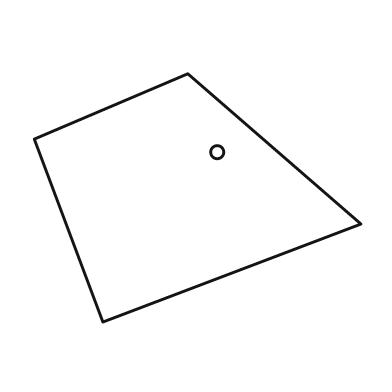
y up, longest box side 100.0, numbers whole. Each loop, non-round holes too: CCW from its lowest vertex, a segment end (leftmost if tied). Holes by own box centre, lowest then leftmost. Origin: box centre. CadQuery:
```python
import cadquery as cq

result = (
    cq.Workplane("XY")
    .moveTo(-29.0, -38.0)
    .lineTo(50.0, -8.0)
    .lineTo(-3.0, 38.0)
    .lineTo(-50.0, 18.0)
    .close()
    .moveTo(6.0, 14.0)
    .circle(2.0)
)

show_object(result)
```